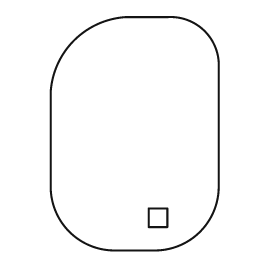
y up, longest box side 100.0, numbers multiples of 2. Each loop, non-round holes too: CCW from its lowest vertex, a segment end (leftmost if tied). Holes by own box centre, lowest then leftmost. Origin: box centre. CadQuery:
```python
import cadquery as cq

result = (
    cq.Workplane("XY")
    .moveTo(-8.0, -50.0)
    .lineTo(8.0, -50.0)
    .threePointArc((28.0, -42.0), (36.0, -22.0))
    .lineTo(36.0, 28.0)
    .threePointArc((30.0, 44.0), (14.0, 50.0))
    .lineTo(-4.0, 50.0)
    .threePointArc((-26.0, 40.0), (-36.0, 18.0))
    .lineTo(-36.0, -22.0)
    .threePointArc((-28.0, -42.0), (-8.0, -50.0))
    .close()
    .moveTo(6.0, -40.0)
    .lineTo(14.0, -40.0)
    .lineTo(14.0, -32.0)
    .lineTo(6.0, -32.0)
    .close()
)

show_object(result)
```